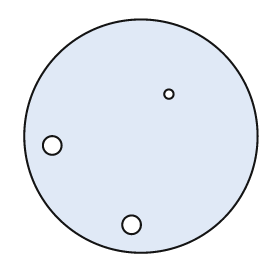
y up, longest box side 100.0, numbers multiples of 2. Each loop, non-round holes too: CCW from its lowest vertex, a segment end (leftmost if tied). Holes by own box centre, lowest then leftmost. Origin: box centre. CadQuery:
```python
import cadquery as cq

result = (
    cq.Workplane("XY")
    .moveTo(0.0, 0.0)
    .circle(50.0)
    .moveTo(-4.0, -38.0)
    .circle(4.0)
    .moveTo(-38.0, -4.0)
    .circle(4.0)
    .moveTo(12.0, 18.0)
    .circle(2.0)
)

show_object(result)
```